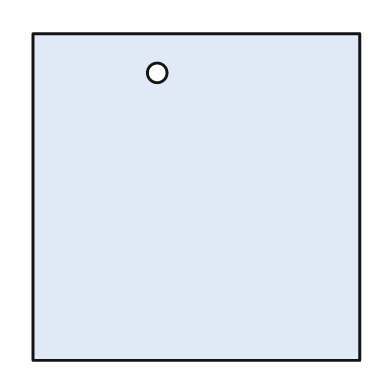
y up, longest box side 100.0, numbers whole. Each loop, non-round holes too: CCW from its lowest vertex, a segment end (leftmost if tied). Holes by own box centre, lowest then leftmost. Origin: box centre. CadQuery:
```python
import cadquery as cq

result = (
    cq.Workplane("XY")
    .moveTo(-50.0, -50.0)
    .lineTo(50.0, -50.0)
    .lineTo(50.0, 50.0)
    .lineTo(-50.0, 50.0)
    .close()
    .moveTo(-12.0, 38.0)
    .circle(3.0)
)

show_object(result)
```